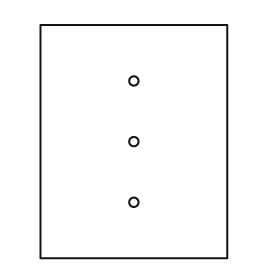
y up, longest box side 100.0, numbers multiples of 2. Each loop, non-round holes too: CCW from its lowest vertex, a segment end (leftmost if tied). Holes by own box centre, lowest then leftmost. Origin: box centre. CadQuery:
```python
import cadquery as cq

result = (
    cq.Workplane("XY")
    .moveTo(-40.0, -50.0)
    .lineTo(40.0, -50.0)
    .lineTo(40.0, 50.0)
    .lineTo(-40.0, 50.0)
    .close()
    .moveTo(0.0, -26.0)
    .circle(2.0)
    .moveTo(0.0, 0.0)
    .circle(2.0)
    .moveTo(0.0, 26.0)
    .circle(2.0)
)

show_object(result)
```